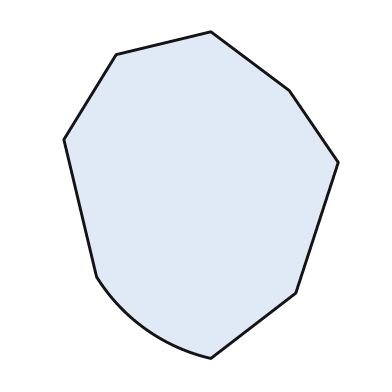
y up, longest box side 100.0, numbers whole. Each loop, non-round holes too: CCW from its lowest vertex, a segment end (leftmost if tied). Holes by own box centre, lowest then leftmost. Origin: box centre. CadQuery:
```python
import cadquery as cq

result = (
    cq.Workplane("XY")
    .moveTo(3.0, -50.0)
    .lineTo(29.0, -30.0)
    .lineTo(42.0, 10.0)
    .lineTo(27.0, 32.0)
    .lineTo(3.0, 50.0)
    .lineTo(-26.0, 43.0)
    .lineTo(-42.0, 17.0)
    .lineTo(-32.0, -25.0)
    .threePointArc((-17.0, -41.0), (3.0, -50.0))
    .close()
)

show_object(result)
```